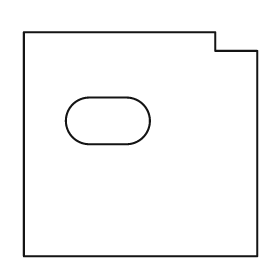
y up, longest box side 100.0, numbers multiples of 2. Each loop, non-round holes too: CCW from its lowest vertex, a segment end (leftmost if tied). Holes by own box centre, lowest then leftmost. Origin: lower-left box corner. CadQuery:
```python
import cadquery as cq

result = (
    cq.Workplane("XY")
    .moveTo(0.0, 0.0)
    .lineTo(100.0, 0.0)
    .lineTo(100.0, 88.0)
    .lineTo(82.0, 88.0)
    .lineTo(82.0, 96.0)
    .lineTo(0.0, 96.0)
    .close()
    .moveTo(28.0, 48.0)
    .lineTo(44.0, 48.0)
    .threePointArc((54.0, 58.0), (44.0, 68.0))
    .lineTo(28.0, 68.0)
    .threePointArc((18.0, 58.0), (28.0, 48.0))
    .close()
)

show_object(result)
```